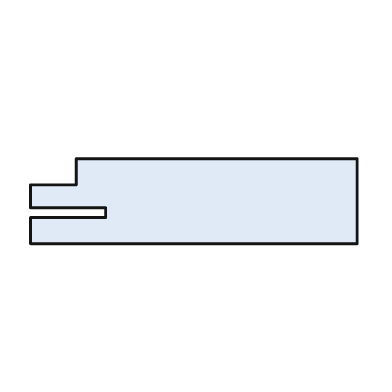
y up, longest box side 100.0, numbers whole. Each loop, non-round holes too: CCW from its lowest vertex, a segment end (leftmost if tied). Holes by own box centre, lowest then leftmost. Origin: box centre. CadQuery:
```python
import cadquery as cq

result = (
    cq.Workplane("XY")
    .moveTo(-50.0, -13.0)
    .lineTo(50.0, -13.0)
    .lineTo(50.0, 13.0)
    .lineTo(-36.0, 13.0)
    .lineTo(-36.0, 5.0)
    .lineTo(-50.0, 5.0)
    .lineTo(-50.0, -2.0)
    .lineTo(-27.0, -2.0)
    .lineTo(-27.0, -5.0)
    .lineTo(-50.0, -5.0)
    .close()
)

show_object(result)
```